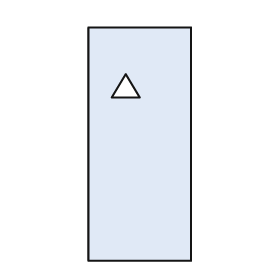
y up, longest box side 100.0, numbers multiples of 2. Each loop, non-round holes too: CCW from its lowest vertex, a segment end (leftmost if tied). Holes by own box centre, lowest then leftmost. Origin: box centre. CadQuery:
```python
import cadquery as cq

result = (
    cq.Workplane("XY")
    .moveTo(-22.0, -50.0)
    .lineTo(22.0, -50.0)
    .lineTo(22.0, 50.0)
    .lineTo(-22.0, 50.0)
    .close()
    .moveTo(-12.0, 20.0)
    .lineTo(0.0, 20.0)
    .lineTo(-6.0, 30.0)
    .close()
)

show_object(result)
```